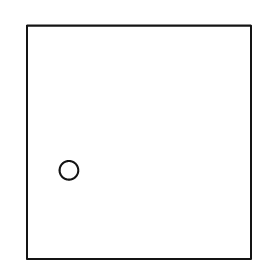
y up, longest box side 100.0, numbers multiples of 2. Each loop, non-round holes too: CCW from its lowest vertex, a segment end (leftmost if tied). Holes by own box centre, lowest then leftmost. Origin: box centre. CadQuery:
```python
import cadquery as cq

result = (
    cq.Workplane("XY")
    .moveTo(-48.0, -50.0)
    .lineTo(48.0, -50.0)
    .lineTo(48.0, 50.0)
    .lineTo(-48.0, 50.0)
    .close()
    .moveTo(-30.0, -12.0)
    .circle(4.0)
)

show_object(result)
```